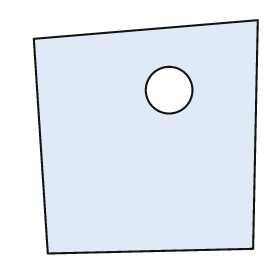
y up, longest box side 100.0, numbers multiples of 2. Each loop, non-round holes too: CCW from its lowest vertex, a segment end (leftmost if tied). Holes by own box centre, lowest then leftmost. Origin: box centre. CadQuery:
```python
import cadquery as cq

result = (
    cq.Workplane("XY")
    .moveTo(-42.0, -50.0)
    .lineTo(46.0, -48.0)
    .lineTo(48.0, 50.0)
    .lineTo(-48.0, 42.0)
    .close()
    .moveTo(10.0, 20.0)
    .circle(10.0)
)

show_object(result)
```